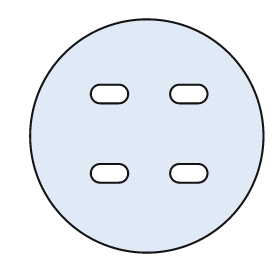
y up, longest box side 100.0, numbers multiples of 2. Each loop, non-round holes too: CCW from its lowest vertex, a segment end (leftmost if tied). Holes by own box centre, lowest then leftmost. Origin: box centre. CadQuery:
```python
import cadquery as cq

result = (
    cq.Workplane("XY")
    .moveTo(0.0, 0.0)
    .circle(50.0)
    .moveTo(-20.0, -20.0)
    .lineTo(-12.0, -20.0)
    .threePointArc((-8.0, -16.0), (-12.0, -12.0))
    .lineTo(-20.0, -12.0)
    .threePointArc((-24.0, -16.0), (-20.0, -20.0))
    .close()
    .moveTo(14.0, -20.0)
    .lineTo(22.0, -20.0)
    .threePointArc((26.0, -16.0), (22.0, -12.0))
    .lineTo(14.0, -12.0)
    .threePointArc((10.0, -16.0), (14.0, -20.0))
    .close()
    .moveTo(-20.0, 14.0)
    .lineTo(-12.0, 14.0)
    .threePointArc((-8.0, 18.0), (-12.0, 22.0))
    .lineTo(-20.0, 22.0)
    .threePointArc((-24.0, 18.0), (-20.0, 14.0))
    .close()
    .moveTo(14.0, 14.0)
    .lineTo(22.0, 14.0)
    .threePointArc((26.0, 18.0), (22.0, 22.0))
    .lineTo(14.0, 22.0)
    .threePointArc((10.0, 18.0), (14.0, 14.0))
    .close()
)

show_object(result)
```